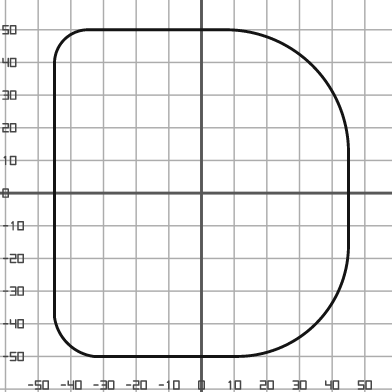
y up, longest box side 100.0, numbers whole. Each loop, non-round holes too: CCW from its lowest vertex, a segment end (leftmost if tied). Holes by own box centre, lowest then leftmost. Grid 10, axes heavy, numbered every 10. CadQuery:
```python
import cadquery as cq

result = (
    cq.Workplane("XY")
    .moveTo(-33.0, -50.0)
    .lineTo(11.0, -50.0)
    .threePointArc((35.0, -40.0), (45.0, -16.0))
    .lineTo(45.0, 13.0)
    .threePointArc((34.0, 39.0), (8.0, 50.0))
    .lineTo(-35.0, 50.0)
    .threePointArc((-42.0, 47.0), (-45.0, 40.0))
    .lineTo(-45.0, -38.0)
    .threePointArc((-41.0, -46.0), (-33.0, -50.0))
    .close()
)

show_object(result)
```